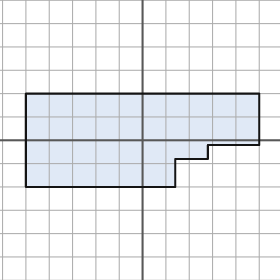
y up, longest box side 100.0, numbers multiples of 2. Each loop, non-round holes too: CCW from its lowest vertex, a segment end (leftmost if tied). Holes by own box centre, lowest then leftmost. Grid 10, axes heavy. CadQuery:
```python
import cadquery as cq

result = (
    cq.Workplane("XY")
    .moveTo(-50.0, -20.0)
    .lineTo(14.0, -20.0)
    .lineTo(14.0, -8.0)
    .lineTo(28.0, -8.0)
    .lineTo(28.0, -2.0)
    .lineTo(50.0, -2.0)
    .lineTo(50.0, 20.0)
    .lineTo(-50.0, 20.0)
    .close()
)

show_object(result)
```